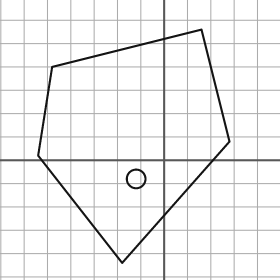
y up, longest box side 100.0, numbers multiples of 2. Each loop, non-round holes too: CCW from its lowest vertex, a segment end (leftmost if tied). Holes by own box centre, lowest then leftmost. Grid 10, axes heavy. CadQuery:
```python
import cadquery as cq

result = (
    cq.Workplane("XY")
    .moveTo(-18.0, -44.0)
    .lineTo(28.0, 8.0)
    .lineTo(16.0, 56.0)
    .lineTo(-48.0, 40.0)
    .lineTo(-54.0, 2.0)
    .close()
    .moveTo(-12.0, -8.0)
    .circle(4.0)
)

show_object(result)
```